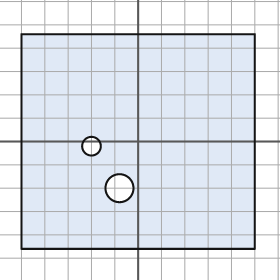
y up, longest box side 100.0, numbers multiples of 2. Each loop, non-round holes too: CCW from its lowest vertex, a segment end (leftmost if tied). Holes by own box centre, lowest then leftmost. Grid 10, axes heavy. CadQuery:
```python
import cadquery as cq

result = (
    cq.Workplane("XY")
    .moveTo(-50.0, -46.0)
    .lineTo(50.0, -46.0)
    .lineTo(50.0, 46.0)
    .lineTo(-50.0, 46.0)
    .close()
    .moveTo(-8.0, -20.0)
    .circle(6.0)
    .moveTo(-20.0, -2.0)
    .circle(4.0)
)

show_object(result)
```